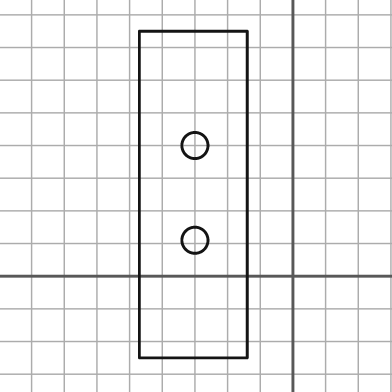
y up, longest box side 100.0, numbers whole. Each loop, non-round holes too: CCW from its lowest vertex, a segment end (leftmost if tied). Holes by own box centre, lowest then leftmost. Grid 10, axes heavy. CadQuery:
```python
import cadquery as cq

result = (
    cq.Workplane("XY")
    .moveTo(-47.0, -25.0)
    .lineTo(-14.0, -25.0)
    .lineTo(-14.0, 75.0)
    .lineTo(-47.0, 75.0)
    .close()
    .moveTo(-30.0, 11.0)
    .circle(4.0)
    .moveTo(-30.0, 40.0)
    .circle(4.0)
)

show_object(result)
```